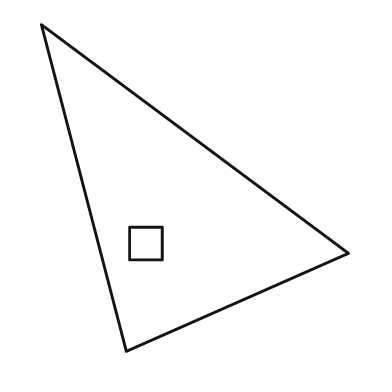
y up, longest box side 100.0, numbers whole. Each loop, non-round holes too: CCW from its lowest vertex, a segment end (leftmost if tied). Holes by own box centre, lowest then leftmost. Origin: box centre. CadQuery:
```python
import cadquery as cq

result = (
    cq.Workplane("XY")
    .moveTo(-21.0, -50.0)
    .lineTo(47.0, -20.0)
    .lineTo(-47.0, 50.0)
    .close()
    .moveTo(-20.0, -22.0)
    .lineTo(-10.0, -22.0)
    .lineTo(-10.0, -12.0)
    .lineTo(-20.0, -12.0)
    .close()
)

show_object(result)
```